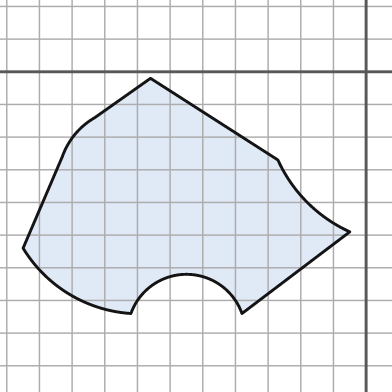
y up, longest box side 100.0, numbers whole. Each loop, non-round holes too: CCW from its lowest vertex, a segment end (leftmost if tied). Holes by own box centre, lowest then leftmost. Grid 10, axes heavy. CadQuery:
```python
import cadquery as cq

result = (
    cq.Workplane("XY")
    .moveTo(-72.0, -74.0)
    .threePointArc((-55.0, -62.0), (-38.0, -74.0))
    .lineTo(-5.0, -49.0)
    .threePointArc((-18.0, -40.0), (-27.0, -27.0))
    .lineTo(-66.0, -2.0)
    .lineTo(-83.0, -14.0)
    .threePointArc((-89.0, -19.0), (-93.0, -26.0))
    .lineTo(-105.0, -54.0)
    .threePointArc((-91.0, -68.0), (-72.0, -74.0))
    .close()
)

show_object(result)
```